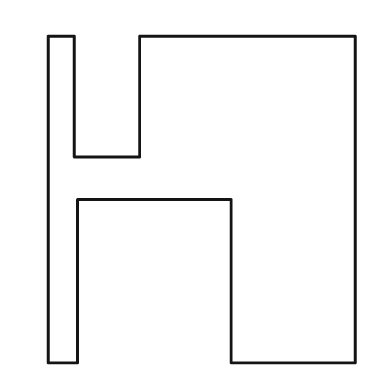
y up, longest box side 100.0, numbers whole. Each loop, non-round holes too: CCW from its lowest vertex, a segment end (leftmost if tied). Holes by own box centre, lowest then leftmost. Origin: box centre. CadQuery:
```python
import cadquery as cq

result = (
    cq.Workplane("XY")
    .moveTo(-47.0, -50.0)
    .lineTo(-38.0, -50.0)
    .lineTo(-38.0, 0.0)
    .lineTo(9.0, 0.0)
    .lineTo(9.0, -50.0)
    .lineTo(47.0, -50.0)
    .lineTo(47.0, 50.0)
    .lineTo(-19.0, 50.0)
    .lineTo(-19.0, 13.0)
    .lineTo(-39.0, 13.0)
    .lineTo(-39.0, 50.0)
    .lineTo(-47.0, 50.0)
    .close()
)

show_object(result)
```